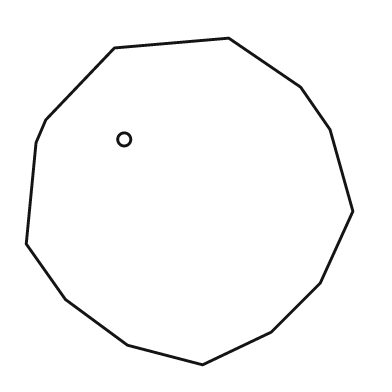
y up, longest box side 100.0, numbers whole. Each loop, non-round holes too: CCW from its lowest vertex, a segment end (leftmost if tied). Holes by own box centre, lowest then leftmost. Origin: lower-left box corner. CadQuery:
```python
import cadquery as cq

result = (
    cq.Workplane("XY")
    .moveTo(54.0, 0.0)
    .lineTo(75.0, 10.0)
    .lineTo(90.0, 25.0)
    .lineTo(100.0, 47.0)
    .lineTo(93.0, 72.0)
    .lineTo(84.0, 85.0)
    .lineTo(62.0, 100.0)
    .lineTo(27.0, 97.0)
    .lineTo(6.0, 75.0)
    .lineTo(3.0, 68.0)
    .lineTo(0.0, 37.0)
    .lineTo(12.0, 20.0)
    .lineTo(31.0, 6.0)
    .close()
    .moveTo(30.0, 69.0)
    .circle(2.0)
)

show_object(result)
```